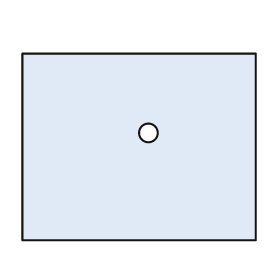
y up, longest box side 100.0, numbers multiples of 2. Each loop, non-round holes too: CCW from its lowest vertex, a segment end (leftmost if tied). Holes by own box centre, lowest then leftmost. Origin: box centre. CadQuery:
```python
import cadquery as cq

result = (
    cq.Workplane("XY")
    .moveTo(-50.0, -40.0)
    .lineTo(50.0, -40.0)
    .lineTo(50.0, 40.0)
    .lineTo(-50.0, 40.0)
    .close()
    .moveTo(4.0, 6.0)
    .circle(4.0)
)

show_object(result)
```